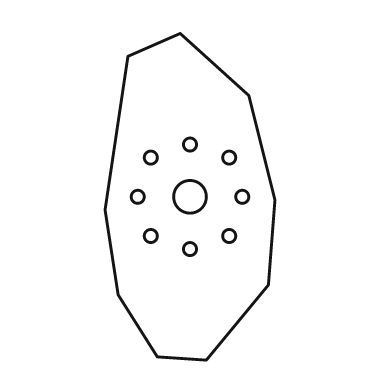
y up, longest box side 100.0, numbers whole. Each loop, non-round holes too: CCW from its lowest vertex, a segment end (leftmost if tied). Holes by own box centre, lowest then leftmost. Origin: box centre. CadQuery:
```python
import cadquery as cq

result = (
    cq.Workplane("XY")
    .moveTo(5.0, -50.0)
    .lineTo(24.0, -27.0)
    .lineTo(26.0, -1.0)
    .lineTo(18.0, 31.0)
    .lineTo(-3.0, 50.0)
    .lineTo(-19.0, 43.0)
    .lineTo(-26.0, -4.0)
    .lineTo(-22.0, -30.0)
    .lineTo(-10.0, -49.0)
    .close()
    .moveTo(0.0, -16.0)
    .circle(2.0)
    .moveTo(-12.0, -12.0)
    .circle(2.0)
    .moveTo(12.0, -12.0)
    .circle(2.0)
    .moveTo(-16.0, 0.0)
    .circle(2.0)
    .moveTo(0.0, 0.0)
    .circle(5.0)
    .moveTo(16.0, 0.0)
    .circle(2.0)
    .moveTo(-12.0, 12.0)
    .circle(2.0)
    .moveTo(12.0, 12.0)
    .circle(2.0)
    .moveTo(0.0, 16.0)
    .circle(2.0)
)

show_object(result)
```